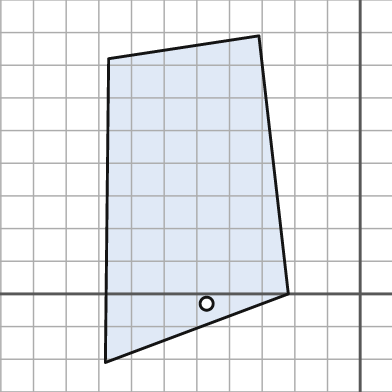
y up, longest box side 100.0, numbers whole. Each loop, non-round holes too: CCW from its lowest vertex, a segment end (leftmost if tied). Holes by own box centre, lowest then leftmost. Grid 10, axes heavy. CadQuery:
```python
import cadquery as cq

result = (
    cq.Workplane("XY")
    .moveTo(-78.0, -21.0)
    .lineTo(-22.0, 0.0)
    .lineTo(-31.0, 79.0)
    .lineTo(-77.0, 72.0)
    .close()
    .moveTo(-47.0, -3.0)
    .circle(2.0)
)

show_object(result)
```